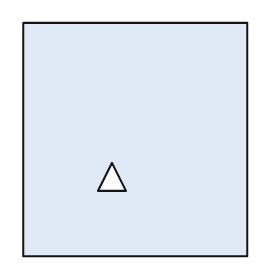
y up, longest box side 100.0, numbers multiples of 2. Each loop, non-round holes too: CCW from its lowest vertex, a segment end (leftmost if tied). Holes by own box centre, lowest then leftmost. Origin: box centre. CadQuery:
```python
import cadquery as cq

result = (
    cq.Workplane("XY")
    .moveTo(-48.0, -50.0)
    .lineTo(48.0, -50.0)
    .lineTo(48.0, 50.0)
    .lineTo(-48.0, 50.0)
    .close()
    .moveTo(-16.0, -22.0)
    .lineTo(-4.0, -22.0)
    .lineTo(-10.0, -10.0)
    .close()
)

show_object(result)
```